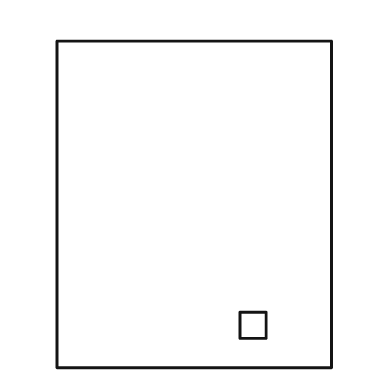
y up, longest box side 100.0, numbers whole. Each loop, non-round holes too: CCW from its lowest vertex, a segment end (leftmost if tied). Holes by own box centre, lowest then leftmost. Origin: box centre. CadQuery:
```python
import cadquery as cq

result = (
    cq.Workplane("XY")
    .moveTo(-42.0, -50.0)
    .lineTo(42.0, -50.0)
    .lineTo(42.0, 50.0)
    .lineTo(-42.0, 50.0)
    .close()
    .moveTo(14.0, -41.0)
    .lineTo(22.0, -41.0)
    .lineTo(22.0, -33.0)
    .lineTo(14.0, -33.0)
    .close()
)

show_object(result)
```